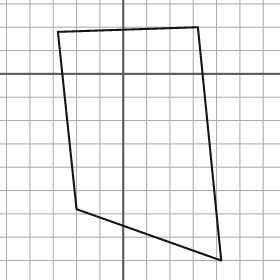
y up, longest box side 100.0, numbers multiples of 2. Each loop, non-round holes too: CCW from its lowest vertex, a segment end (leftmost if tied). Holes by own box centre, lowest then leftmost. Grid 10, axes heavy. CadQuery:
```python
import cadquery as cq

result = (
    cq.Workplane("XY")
    .moveTo(42.0, -80.0)
    .lineTo(32.0, 20.0)
    .lineTo(-28.0, 18.0)
    .lineTo(-20.0, -58.0)
    .close()
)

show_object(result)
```